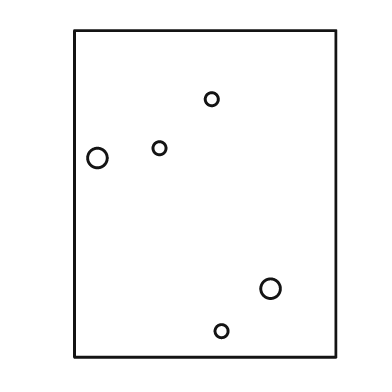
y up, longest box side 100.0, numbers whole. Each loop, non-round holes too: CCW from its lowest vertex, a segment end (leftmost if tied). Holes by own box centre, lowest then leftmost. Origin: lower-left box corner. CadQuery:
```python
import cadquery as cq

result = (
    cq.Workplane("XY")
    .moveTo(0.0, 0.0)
    .lineTo(80.0, 0.0)
    .lineTo(80.0, 100.0)
    .lineTo(0.0, 100.0)
    .close()
    .moveTo(45.0, 8.0)
    .circle(2.0)
    .moveTo(60.0, 21.0)
    .circle(3.0)
    .moveTo(7.0, 61.0)
    .circle(3.0)
    .moveTo(26.0, 64.0)
    .circle(2.0)
    .moveTo(42.0, 79.0)
    .circle(2.0)
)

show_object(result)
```